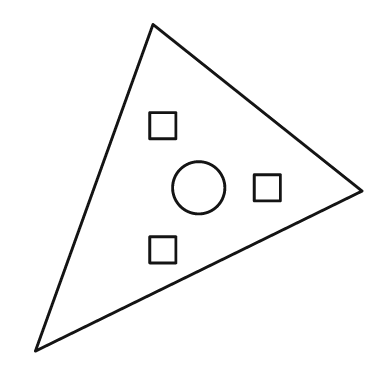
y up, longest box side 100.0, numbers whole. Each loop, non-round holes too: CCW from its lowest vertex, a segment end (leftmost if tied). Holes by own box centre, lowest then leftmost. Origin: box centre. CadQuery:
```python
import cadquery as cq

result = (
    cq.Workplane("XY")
    .moveTo(-50.0, -50.0)
    .lineTo(50.0, -1.0)
    .lineTo(-14.0, 50.0)
    .close()
    .moveTo(-15.0, -23.0)
    .lineTo(-7.0, -23.0)
    .lineTo(-7.0, -15.0)
    .lineTo(-15.0, -15.0)
    .close()
    .moveTo(0.0, 0.0)
    .circle(8.0)
    .moveTo(17.0, -4.0)
    .lineTo(25.0, -4.0)
    .lineTo(25.0, 4.0)
    .lineTo(17.0, 4.0)
    .close()
    .moveTo(-15.0, 15.0)
    .lineTo(-7.0, 15.0)
    .lineTo(-7.0, 23.0)
    .lineTo(-15.0, 23.0)
    .close()
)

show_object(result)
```